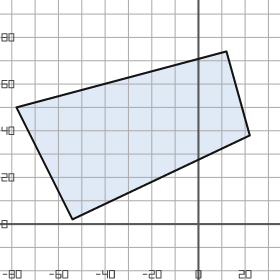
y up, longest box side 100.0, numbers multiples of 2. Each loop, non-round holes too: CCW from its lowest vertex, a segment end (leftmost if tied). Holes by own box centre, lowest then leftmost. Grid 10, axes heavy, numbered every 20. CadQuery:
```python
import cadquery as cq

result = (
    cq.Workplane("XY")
    .moveTo(-54.0, 2.0)
    .lineTo(22.0, 38.0)
    .lineTo(12.0, 74.0)
    .lineTo(-78.0, 50.0)
    .close()
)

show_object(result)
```